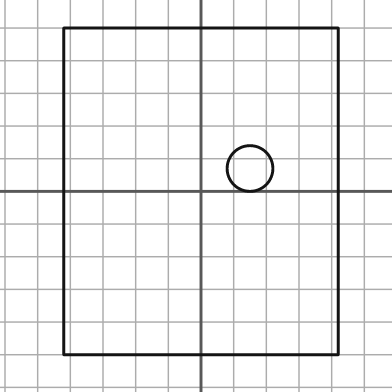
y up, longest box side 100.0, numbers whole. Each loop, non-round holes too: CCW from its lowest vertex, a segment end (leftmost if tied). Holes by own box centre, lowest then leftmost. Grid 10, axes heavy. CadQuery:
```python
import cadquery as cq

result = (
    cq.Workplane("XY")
    .moveTo(-42.0, -50.0)
    .lineTo(42.0, -50.0)
    .lineTo(42.0, 50.0)
    .lineTo(-42.0, 50.0)
    .close()
    .moveTo(15.0, 7.0)
    .circle(7.0)
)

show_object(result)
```